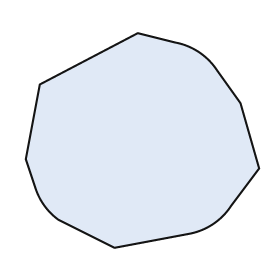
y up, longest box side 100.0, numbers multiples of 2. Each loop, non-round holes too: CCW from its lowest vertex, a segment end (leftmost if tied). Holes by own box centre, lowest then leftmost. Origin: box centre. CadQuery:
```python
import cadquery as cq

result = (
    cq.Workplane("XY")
    .moveTo(-12.0, -46.0)
    .lineTo(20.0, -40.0)
    .threePointArc((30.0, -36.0), (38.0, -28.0))
    .lineTo(50.0, -12.0)
    .lineTo(42.0, 16.0)
    .lineTo(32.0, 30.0)
    .threePointArc((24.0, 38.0), (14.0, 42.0))
    .lineTo(-2.0, 46.0)
    .lineTo(-44.0, 24.0)
    .lineTo(-50.0, -8.0)
    .lineTo(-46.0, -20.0)
    .threePointArc((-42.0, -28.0), (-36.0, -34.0))
    .close()
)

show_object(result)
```